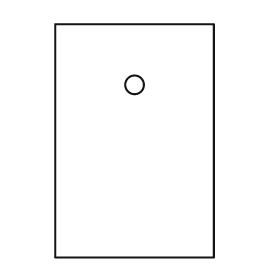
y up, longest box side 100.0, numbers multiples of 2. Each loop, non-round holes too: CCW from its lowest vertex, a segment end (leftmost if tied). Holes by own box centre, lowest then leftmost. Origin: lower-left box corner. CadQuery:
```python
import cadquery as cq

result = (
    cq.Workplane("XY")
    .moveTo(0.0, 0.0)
    .lineTo(68.0, 0.0)
    .lineTo(68.0, 100.0)
    .lineTo(0.0, 100.0)
    .close()
    .moveTo(34.0, 74.0)
    .circle(4.0)
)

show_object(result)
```